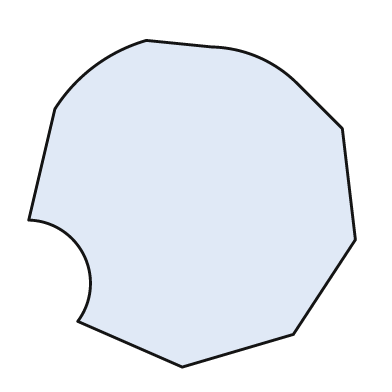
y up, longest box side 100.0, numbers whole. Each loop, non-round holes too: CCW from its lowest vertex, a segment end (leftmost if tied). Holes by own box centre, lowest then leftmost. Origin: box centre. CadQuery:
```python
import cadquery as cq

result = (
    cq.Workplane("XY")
    .moveTo(-3.0, -50.0)
    .lineTo(31.0, -40.0)
    .lineTo(50.0, -11.0)
    .lineTo(46.0, 23.0)
    .lineTo(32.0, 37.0)
    .threePointArc((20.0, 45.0), (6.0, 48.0))
    .lineTo(-14.0, 50.0)
    .threePointArc((-30.0, 42.0), (-42.0, 29.0))
    .lineTo(-50.0, -5.0)
    .threePointArc((-33.0, -16.0), (-35.0, -36.0))
    .close()
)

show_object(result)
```